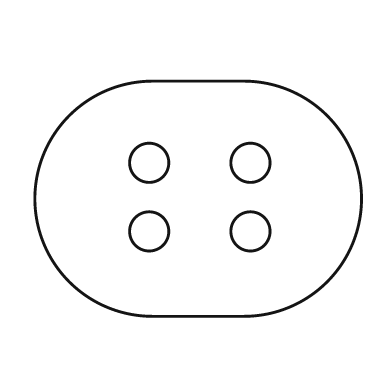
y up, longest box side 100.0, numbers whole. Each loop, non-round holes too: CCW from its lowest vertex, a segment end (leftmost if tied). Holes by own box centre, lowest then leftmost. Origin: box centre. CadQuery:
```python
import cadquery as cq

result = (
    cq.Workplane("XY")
    .moveTo(-14.0, -36.0)
    .lineTo(14.0, -36.0)
    .threePointArc((50.0, 0.0), (14.0, 36.0))
    .lineTo(-14.0, 36.0)
    .threePointArc((-50.0, 0.0), (-14.0, -36.0))
    .close()
    .moveTo(-15.0, -10.0)
    .circle(6.0)
    .moveTo(16.0, -10.0)
    .circle(6.0)
    .moveTo(-15.0, 11.0)
    .circle(6.0)
    .moveTo(16.0, 11.0)
    .circle(6.0)
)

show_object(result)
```